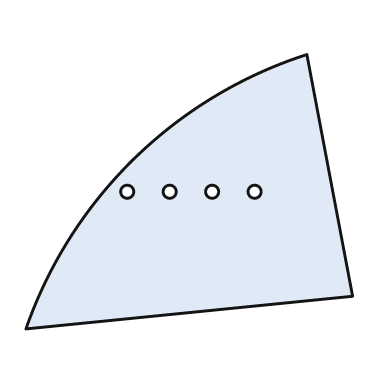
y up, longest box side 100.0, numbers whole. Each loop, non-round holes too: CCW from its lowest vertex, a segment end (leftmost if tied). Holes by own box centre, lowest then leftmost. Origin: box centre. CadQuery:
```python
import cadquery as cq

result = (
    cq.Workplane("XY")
    .moveTo(-50.0, -42.0)
    .lineTo(50.0, -32.0)
    .lineTo(36.0, 42.0)
    .threePointArc((-17.0, 10.0), (-50.0, -42.0))
    .close()
    .moveTo(-19.0, 0.0)
    .circle(2.0)
    .moveTo(-6.0, 0.0)
    .circle(2.0)
    .moveTo(7.0, 0.0)
    .circle(2.0)
    .moveTo(20.0, 0.0)
    .circle(2.0)
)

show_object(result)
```